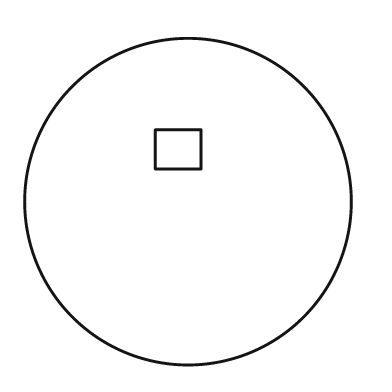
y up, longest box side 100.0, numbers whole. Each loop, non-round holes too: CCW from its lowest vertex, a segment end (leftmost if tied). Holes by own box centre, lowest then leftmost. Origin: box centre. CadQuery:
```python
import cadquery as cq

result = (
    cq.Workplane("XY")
    .moveTo(0.0, 0.0)
    .circle(50.0)
    .moveTo(-10.0, 10.0)
    .lineTo(4.0, 10.0)
    .lineTo(4.0, 22.0)
    .lineTo(-10.0, 22.0)
    .close()
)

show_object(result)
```